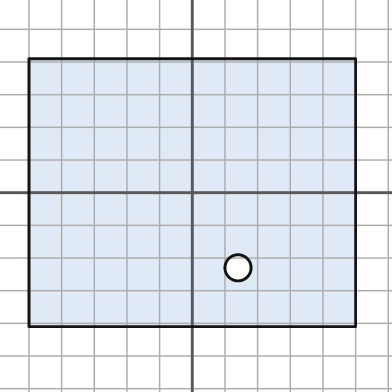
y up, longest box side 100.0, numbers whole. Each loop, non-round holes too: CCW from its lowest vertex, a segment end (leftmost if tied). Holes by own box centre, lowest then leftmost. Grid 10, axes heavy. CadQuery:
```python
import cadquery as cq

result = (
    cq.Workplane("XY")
    .moveTo(-50.0, -41.0)
    .lineTo(50.0, -41.0)
    .lineTo(50.0, 41.0)
    .lineTo(-50.0, 41.0)
    .close()
    .moveTo(14.0, -23.0)
    .circle(4.0)
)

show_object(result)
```